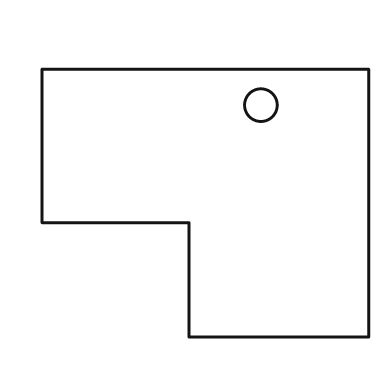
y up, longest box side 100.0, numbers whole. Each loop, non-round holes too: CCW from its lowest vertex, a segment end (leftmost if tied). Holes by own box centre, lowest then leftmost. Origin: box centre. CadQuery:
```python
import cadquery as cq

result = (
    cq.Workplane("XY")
    .moveTo(-5.0, -41.0)
    .lineTo(50.0, -41.0)
    .lineTo(50.0, 41.0)
    .lineTo(-50.0, 41.0)
    .lineTo(-50.0, -6.0)
    .lineTo(-5.0, -6.0)
    .close()
    .moveTo(17.0, 30.0)
    .circle(5.0)
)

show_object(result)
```